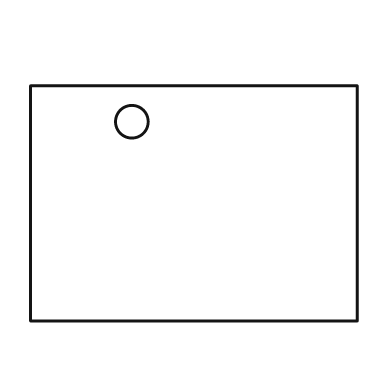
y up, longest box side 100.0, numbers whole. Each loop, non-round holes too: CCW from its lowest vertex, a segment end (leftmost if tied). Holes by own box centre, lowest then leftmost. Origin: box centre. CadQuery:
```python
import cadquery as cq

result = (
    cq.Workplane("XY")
    .moveTo(-50.0, -36.0)
    .lineTo(50.0, -36.0)
    .lineTo(50.0, 36.0)
    .lineTo(-50.0, 36.0)
    .close()
    .moveTo(-19.0, 25.0)
    .circle(5.0)
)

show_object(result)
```